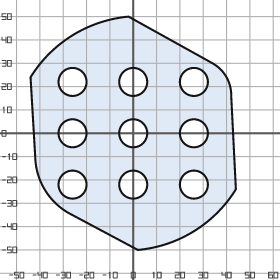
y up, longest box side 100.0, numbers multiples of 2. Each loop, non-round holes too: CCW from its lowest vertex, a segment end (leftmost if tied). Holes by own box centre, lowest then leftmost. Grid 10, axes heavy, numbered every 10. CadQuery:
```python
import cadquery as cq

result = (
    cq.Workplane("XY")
    .moveTo(2.0, -50.0)
    .threePointArc((26.0, -42.0), (44.0, -24.0))
    .lineTo(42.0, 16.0)
    .threePointArc((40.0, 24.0), (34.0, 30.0))
    .lineTo(-2.0, 50.0)
    .threePointArc((-26.0, 42.0), (-44.0, 24.0))
    .lineTo(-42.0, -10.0)
    .threePointArc((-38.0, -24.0), (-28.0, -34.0))
    .close()
    .moveTo(-26.0, -22.0)
    .circle(6.0)
    .moveTo(0.0, -22.0)
    .circle(6.0)
    .moveTo(26.0, -22.0)
    .circle(6.0)
    .moveTo(-26.0, 0.0)
    .circle(6.0)
    .moveTo(0.0, 0.0)
    .circle(6.0)
    .moveTo(26.0, 0.0)
    .circle(6.0)
    .moveTo(-26.0, 22.0)
    .circle(6.0)
    .moveTo(0.0, 22.0)
    .circle(6.0)
    .moveTo(26.0, 22.0)
    .circle(6.0)
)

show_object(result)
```